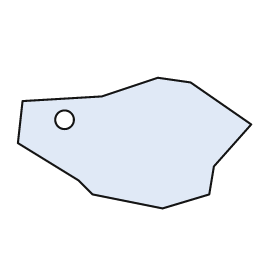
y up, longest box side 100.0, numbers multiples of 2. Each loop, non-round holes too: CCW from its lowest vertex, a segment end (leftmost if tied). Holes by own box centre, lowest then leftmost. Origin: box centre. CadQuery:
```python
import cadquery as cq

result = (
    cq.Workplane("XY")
    .moveTo(12.0, -28.0)
    .lineTo(32.0, -22.0)
    .lineTo(34.0, -10.0)
    .lineTo(50.0, 8.0)
    .lineTo(24.0, 26.0)
    .lineTo(10.0, 28.0)
    .lineTo(-14.0, 20.0)
    .lineTo(-48.0, 18.0)
    .lineTo(-50.0, 0.0)
    .lineTo(-24.0, -16.0)
    .lineTo(-18.0, -22.0)
    .close()
    .moveTo(-30.0, 10.0)
    .circle(4.0)
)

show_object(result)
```